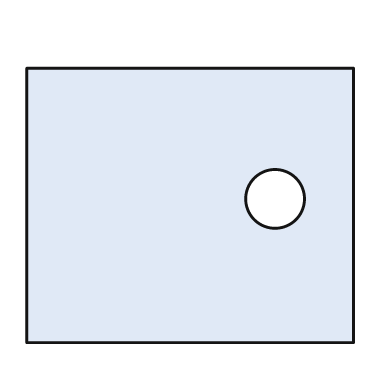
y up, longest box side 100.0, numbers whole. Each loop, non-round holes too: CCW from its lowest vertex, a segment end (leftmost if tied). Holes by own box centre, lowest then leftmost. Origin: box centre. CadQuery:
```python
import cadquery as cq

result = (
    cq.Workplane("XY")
    .moveTo(-50.0, -42.0)
    .lineTo(50.0, -42.0)
    .lineTo(50.0, 42.0)
    .lineTo(-50.0, 42.0)
    .close()
    .moveTo(26.0, 2.0)
    .circle(9.0)
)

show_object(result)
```